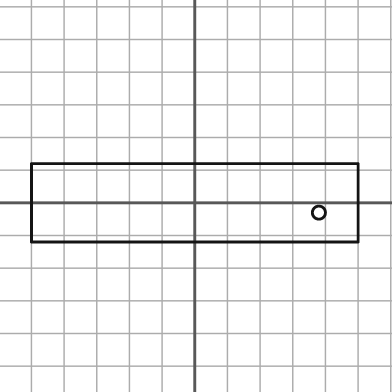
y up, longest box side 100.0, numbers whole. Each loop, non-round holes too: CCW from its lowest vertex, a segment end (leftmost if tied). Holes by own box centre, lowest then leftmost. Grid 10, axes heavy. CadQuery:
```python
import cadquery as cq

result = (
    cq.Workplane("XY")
    .moveTo(-50.0, -12.0)
    .lineTo(50.0, -12.0)
    .lineTo(50.0, 12.0)
    .lineTo(-50.0, 12.0)
    .close()
    .moveTo(38.0, -3.0)
    .circle(2.0)
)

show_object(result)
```